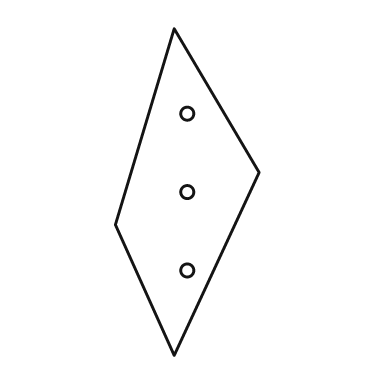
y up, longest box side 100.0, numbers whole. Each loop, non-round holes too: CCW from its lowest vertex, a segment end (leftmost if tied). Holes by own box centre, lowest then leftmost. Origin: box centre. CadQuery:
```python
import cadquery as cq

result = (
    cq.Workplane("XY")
    .moveTo(-4.0, -50.0)
    .lineTo(22.0, 6.0)
    .lineTo(-4.0, 50.0)
    .lineTo(-22.0, -10.0)
    .close()
    .moveTo(0.0, -24.0)
    .circle(2.0)
    .moveTo(0.0, 0.0)
    .circle(2.0)
    .moveTo(0.0, 24.0)
    .circle(2.0)
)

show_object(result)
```